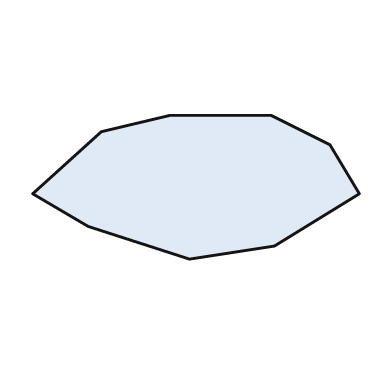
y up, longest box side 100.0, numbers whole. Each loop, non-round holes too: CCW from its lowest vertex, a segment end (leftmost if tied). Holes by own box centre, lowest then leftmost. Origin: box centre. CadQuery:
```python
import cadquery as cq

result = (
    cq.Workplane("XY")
    .moveTo(-2.0, -22.0)
    .lineTo(24.0, -18.0)
    .lineTo(50.0, -2.0)
    .lineTo(41.0, 13.0)
    .lineTo(23.0, 22.0)
    .lineTo(-8.0, 22.0)
    .lineTo(-29.0, 17.0)
    .lineTo(-50.0, -2.0)
    .lineTo(-33.0, -12.0)
    .close()
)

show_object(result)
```